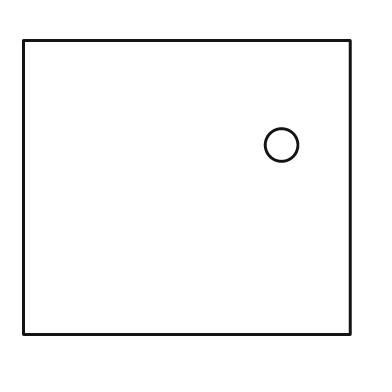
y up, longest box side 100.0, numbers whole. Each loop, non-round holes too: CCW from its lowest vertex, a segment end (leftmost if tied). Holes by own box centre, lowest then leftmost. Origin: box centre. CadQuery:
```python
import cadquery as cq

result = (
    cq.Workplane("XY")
    .moveTo(-50.0, -45.0)
    .lineTo(50.0, -45.0)
    .lineTo(50.0, 45.0)
    .lineTo(-50.0, 45.0)
    .close()
    .moveTo(29.0, 13.0)
    .circle(5.0)
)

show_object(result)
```